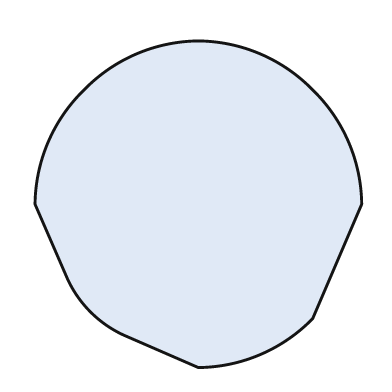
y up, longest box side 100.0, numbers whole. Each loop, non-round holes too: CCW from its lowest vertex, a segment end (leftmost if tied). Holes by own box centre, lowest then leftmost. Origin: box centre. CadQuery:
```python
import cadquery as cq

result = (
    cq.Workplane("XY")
    .moveTo(0.0, -50.0)
    .threePointArc((19.0, -46.0), (35.0, -35.0))
    .lineTo(50.0, 0.0)
    .threePointArc((46.0, 19.0), (35.0, 35.0))
    .threePointArc((19.0, 46.0), (0.0, 50.0))
    .threePointArc((-19.0, 46.0), (-35.0, 35.0))
    .threePointArc((-46.0, 19.0), (-50.0, 0.0))
    .lineTo(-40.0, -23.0)
    .threePointArc((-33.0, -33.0), (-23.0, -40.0))
    .close()
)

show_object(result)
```